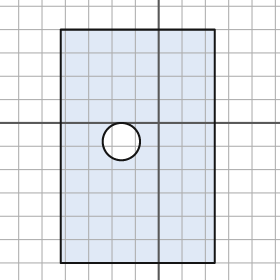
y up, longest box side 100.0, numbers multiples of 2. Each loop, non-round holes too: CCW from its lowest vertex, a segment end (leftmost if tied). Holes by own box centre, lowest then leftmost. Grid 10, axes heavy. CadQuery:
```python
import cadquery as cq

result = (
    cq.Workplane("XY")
    .moveTo(-42.0, -60.0)
    .lineTo(24.0, -60.0)
    .lineTo(24.0, 40.0)
    .lineTo(-42.0, 40.0)
    .close()
    .moveTo(-16.0, -8.0)
    .circle(8.0)
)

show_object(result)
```